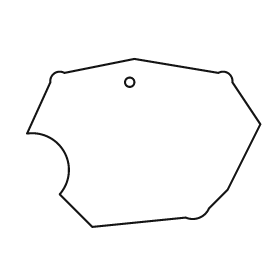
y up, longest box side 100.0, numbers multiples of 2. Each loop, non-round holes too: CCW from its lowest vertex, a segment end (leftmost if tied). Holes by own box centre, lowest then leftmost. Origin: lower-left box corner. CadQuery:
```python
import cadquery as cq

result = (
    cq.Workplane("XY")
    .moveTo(28.0, 0.0)
    .lineTo(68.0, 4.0)
    .threePointArc((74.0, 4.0), (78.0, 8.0))
    .lineTo(86.0, 16.0)
    .lineTo(100.0, 44.0)
    .lineTo(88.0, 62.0)
    .threePointArc((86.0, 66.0), (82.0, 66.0))
    .lineTo(46.0, 72.0)
    .lineTo(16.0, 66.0)
    .threePointArc((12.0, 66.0), (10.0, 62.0))
    .lineTo(0.0, 40.0)
    .threePointArc((16.0, 32.0), (14.0, 14.0))
    .close()
    .moveTo(44.0, 62.0)
    .circle(2.0)
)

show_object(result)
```